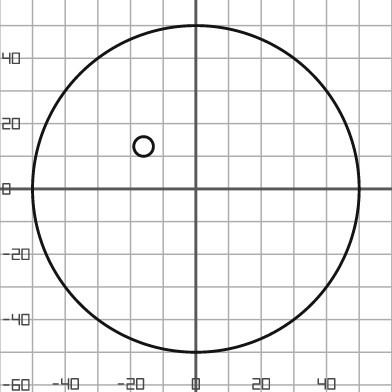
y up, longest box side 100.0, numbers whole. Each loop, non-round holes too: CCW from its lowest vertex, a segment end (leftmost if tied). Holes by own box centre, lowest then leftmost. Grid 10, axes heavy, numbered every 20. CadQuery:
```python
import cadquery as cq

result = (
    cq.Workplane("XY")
    .moveTo(0.0, 0.0)
    .circle(50.0)
    .moveTo(-16.0, 13.0)
    .circle(3.0)
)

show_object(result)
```